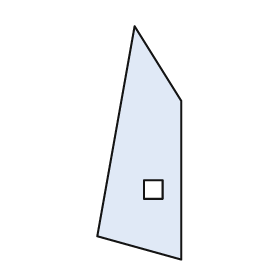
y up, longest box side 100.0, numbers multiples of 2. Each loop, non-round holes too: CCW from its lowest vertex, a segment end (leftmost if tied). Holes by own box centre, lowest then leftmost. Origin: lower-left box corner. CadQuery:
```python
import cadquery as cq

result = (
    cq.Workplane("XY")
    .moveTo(36.0, 0.0)
    .lineTo(36.0, 68.0)
    .lineTo(16.0, 100.0)
    .lineTo(0.0, 10.0)
    .close()
    .moveTo(20.0, 26.0)
    .lineTo(28.0, 26.0)
    .lineTo(28.0, 34.0)
    .lineTo(20.0, 34.0)
    .close()
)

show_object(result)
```